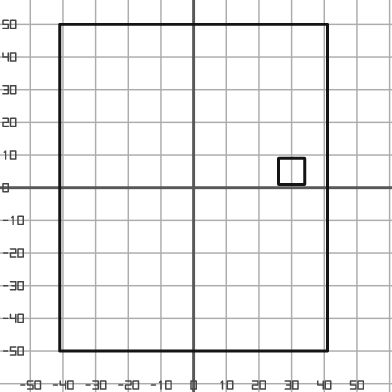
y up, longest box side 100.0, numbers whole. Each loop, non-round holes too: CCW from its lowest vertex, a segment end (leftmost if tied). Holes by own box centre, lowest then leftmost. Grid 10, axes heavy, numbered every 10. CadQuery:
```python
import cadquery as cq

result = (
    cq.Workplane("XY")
    .moveTo(-41.0, -50.0)
    .lineTo(41.0, -50.0)
    .lineTo(41.0, 50.0)
    .lineTo(-41.0, 50.0)
    .close()
    .moveTo(26.0, 1.0)
    .lineTo(34.0, 1.0)
    .lineTo(34.0, 9.0)
    .lineTo(26.0, 9.0)
    .close()
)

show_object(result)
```